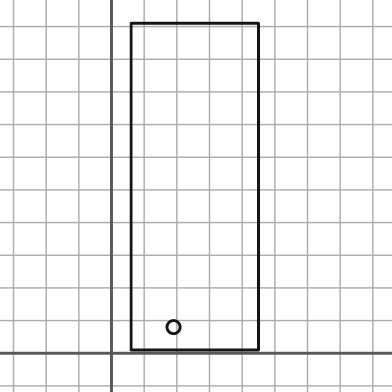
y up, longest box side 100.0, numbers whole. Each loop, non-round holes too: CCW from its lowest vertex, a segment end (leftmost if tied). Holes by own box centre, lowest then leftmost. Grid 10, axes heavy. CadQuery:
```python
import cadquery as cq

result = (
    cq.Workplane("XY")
    .moveTo(6.0, 1.0)
    .lineTo(45.0, 1.0)
    .lineTo(45.0, 101.0)
    .lineTo(6.0, 101.0)
    .close()
    .moveTo(19.0, 8.0)
    .circle(2.0)
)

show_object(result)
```